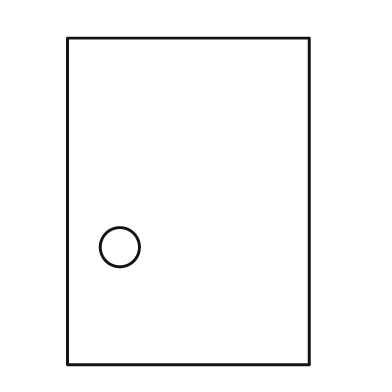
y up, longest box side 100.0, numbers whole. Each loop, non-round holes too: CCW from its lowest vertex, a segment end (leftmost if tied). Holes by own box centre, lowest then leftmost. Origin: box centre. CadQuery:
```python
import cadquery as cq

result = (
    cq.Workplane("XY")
    .moveTo(-37.0, -50.0)
    .lineTo(37.0, -50.0)
    .lineTo(37.0, 50.0)
    .lineTo(-37.0, 50.0)
    .close()
    .moveTo(-21.0, -14.0)
    .circle(6.0)
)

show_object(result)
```